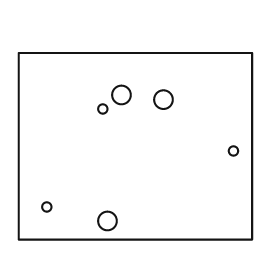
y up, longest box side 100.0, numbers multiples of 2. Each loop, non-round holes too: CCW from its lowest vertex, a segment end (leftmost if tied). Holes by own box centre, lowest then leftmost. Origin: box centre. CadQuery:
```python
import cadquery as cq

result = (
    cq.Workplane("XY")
    .moveTo(-50.0, -40.0)
    .lineTo(50.0, -40.0)
    .lineTo(50.0, 40.0)
    .lineTo(-50.0, 40.0)
    .close()
    .moveTo(-12.0, -32.0)
    .circle(4.0)
    .moveTo(-38.0, -26.0)
    .circle(2.0)
    .moveTo(42.0, -2.0)
    .circle(2.0)
    .moveTo(-14.0, 16.0)
    .circle(2.0)
    .moveTo(12.0, 20.0)
    .circle(4.0)
    .moveTo(-6.0, 22.0)
    .circle(4.0)
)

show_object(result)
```